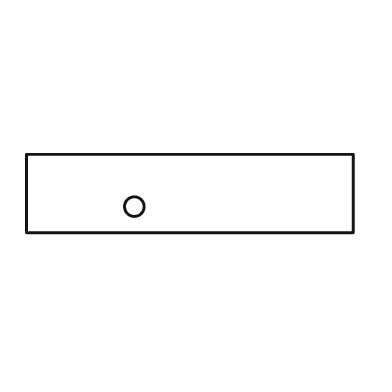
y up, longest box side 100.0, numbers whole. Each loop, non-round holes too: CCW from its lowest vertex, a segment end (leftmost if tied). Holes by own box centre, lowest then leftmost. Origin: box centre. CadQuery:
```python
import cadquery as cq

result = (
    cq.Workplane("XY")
    .moveTo(-50.0, -12.0)
    .lineTo(50.0, -12.0)
    .lineTo(50.0, 12.0)
    .lineTo(-50.0, 12.0)
    .close()
    .moveTo(-17.0, -4.0)
    .circle(3.0)
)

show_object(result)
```